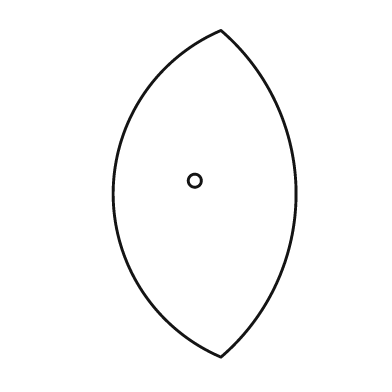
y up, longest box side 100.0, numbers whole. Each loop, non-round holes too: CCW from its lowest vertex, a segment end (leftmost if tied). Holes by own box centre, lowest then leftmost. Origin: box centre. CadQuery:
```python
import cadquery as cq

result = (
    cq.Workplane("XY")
    .moveTo(5.0, -50.0)
    .threePointArc((28.0, 0.0), (5.0, 50.0))
    .threePointArc((-28.0, 0.0), (5.0, -50.0))
    .close()
    .moveTo(-3.0, 4.0)
    .circle(2.0)
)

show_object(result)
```